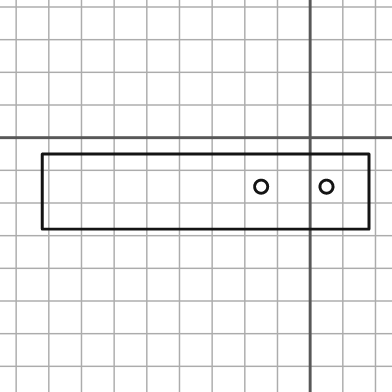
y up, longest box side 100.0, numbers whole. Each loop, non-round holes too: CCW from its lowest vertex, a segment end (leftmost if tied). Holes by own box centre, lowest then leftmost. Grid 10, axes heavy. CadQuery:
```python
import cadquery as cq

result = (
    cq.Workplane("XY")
    .moveTo(-82.0, -28.0)
    .lineTo(18.0, -28.0)
    .lineTo(18.0, -5.0)
    .lineTo(-82.0, -5.0)
    .close()
    .moveTo(-15.0, -15.0)
    .circle(2.0)
    .moveTo(5.0, -15.0)
    .circle(2.0)
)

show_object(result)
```